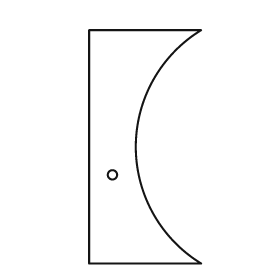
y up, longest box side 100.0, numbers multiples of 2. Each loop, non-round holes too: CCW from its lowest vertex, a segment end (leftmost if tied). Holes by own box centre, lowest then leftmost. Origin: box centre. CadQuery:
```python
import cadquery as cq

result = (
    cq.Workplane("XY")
    .moveTo(-24.0, -50.0)
    .lineTo(24.0, -50.0)
    .threePointArc((-4.0, 0.0), (24.0, 50.0))
    .lineTo(-24.0, 50.0)
    .close()
    .moveTo(-14.0, -12.0)
    .circle(2.0)
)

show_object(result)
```